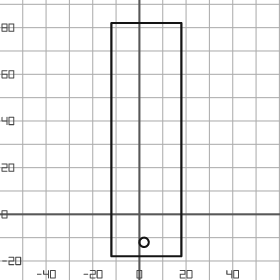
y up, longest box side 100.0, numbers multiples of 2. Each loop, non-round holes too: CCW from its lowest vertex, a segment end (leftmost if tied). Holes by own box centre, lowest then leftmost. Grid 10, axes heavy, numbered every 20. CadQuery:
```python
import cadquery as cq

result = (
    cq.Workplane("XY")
    .moveTo(-12.0, -18.0)
    .lineTo(18.0, -18.0)
    .lineTo(18.0, 82.0)
    .lineTo(-12.0, 82.0)
    .close()
    .moveTo(2.0, -12.0)
    .circle(2.0)
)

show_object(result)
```